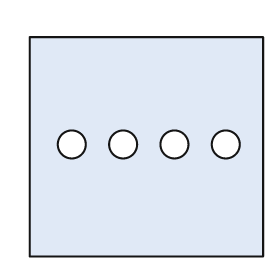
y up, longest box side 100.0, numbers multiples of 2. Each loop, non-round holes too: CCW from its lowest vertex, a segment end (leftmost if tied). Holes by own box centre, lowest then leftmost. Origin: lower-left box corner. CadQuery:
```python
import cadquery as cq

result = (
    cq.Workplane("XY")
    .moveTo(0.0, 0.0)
    .lineTo(100.0, 0.0)
    .lineTo(100.0, 94.0)
    .lineTo(0.0, 94.0)
    .close()
    .moveTo(18.0, 48.0)
    .circle(6.0)
    .moveTo(40.0, 48.0)
    .circle(6.0)
    .moveTo(62.0, 48.0)
    .circle(6.0)
    .moveTo(84.0, 48.0)
    .circle(6.0)
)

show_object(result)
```